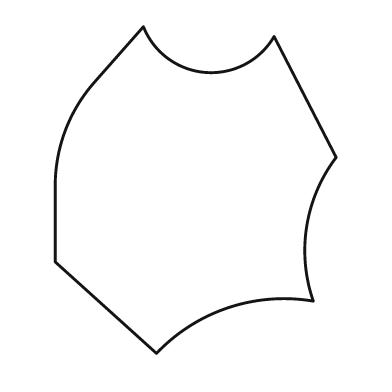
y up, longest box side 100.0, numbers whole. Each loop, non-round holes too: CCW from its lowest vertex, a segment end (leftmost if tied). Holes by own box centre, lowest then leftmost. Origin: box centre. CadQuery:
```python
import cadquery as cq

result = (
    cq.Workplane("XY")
    .moveTo(-12.0, -50.0)
    .threePointArc((10.0, -36.0), (36.0, -34.0))
    .threePointArc((34.0, -11.0), (43.0, 10.0))
    .lineTo(24.0, 47.0)
    .threePointArc((3.0, 36.0), (-16.0, 50.0))
    .lineTo(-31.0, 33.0)
    .threePointArc((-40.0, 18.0), (-43.0, 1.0))
    .lineTo(-43.0, -22.0)
    .close()
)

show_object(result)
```